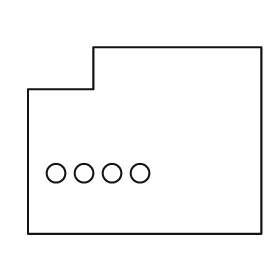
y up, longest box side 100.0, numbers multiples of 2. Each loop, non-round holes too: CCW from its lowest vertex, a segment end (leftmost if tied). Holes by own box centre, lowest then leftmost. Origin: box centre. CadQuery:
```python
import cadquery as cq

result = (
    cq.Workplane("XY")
    .moveTo(-50.0, -40.0)
    .lineTo(50.0, -40.0)
    .lineTo(50.0, 40.0)
    .lineTo(-22.0, 40.0)
    .lineTo(-22.0, 22.0)
    .lineTo(-50.0, 22.0)
    .close()
    .moveTo(-38.0, -14.0)
    .circle(4.0)
    .moveTo(-26.0, -14.0)
    .circle(4.0)
    .moveTo(-14.0, -14.0)
    .circle(4.0)
    .moveTo(-2.0, -14.0)
    .circle(4.0)
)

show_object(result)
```